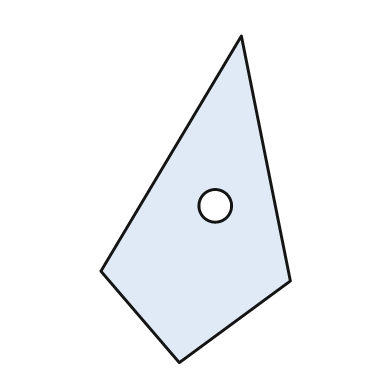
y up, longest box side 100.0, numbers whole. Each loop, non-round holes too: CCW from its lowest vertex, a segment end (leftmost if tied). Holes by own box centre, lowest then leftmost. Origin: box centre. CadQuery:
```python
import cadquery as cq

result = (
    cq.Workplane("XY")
    .moveTo(-5.0, -50.0)
    .lineTo(29.0, -25.0)
    .lineTo(14.0, 50.0)
    .lineTo(-29.0, -22.0)
    .close()
    .moveTo(6.0, -2.0)
    .circle(5.0)
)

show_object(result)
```